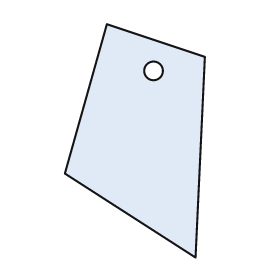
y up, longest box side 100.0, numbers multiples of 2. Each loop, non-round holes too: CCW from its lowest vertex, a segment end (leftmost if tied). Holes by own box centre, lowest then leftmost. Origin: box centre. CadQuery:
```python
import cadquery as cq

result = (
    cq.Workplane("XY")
    .moveTo(26.0, -50.0)
    .lineTo(30.0, 36.0)
    .lineTo(-12.0, 50.0)
    .lineTo(-30.0, -14.0)
    .close()
    .moveTo(8.0, 30.0)
    .circle(4.0)
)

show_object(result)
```